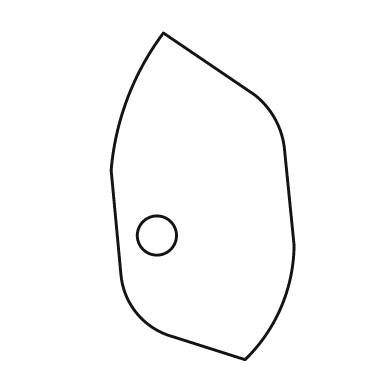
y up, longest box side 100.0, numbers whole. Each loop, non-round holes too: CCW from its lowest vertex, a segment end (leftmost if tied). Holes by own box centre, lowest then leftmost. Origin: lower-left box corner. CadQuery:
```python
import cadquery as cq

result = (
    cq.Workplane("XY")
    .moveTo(41.0, 0.0)
    .threePointArc((52.0, 16.0), (56.0, 35.0))
    .lineTo(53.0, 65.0)
    .threePointArc((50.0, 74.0), (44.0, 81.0))
    .lineTo(16.0, 100.0)
    .threePointArc((5.0, 80.0), (0.0, 58.0))
    .lineTo(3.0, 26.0)
    .threePointArc((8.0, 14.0), (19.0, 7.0))
    .close()
    .moveTo(14.0, 38.0)
    .circle(6.0)
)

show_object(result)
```